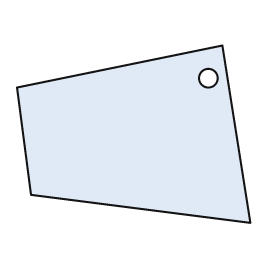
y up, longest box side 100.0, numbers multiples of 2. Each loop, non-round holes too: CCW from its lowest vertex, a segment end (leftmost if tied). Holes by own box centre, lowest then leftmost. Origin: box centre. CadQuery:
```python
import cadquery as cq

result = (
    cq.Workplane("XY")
    .moveTo(50.0, -38.0)
    .lineTo(38.0, 38.0)
    .lineTo(-50.0, 20.0)
    .lineTo(-44.0, -26.0)
    .close()
    .moveTo(32.0, 24.0)
    .circle(4.0)
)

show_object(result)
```